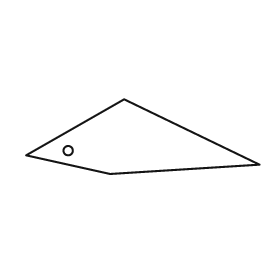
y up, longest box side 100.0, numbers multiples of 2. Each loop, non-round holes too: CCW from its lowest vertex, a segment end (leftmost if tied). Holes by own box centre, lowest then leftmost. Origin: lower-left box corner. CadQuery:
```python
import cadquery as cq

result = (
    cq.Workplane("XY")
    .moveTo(36.0, 0.0)
    .lineTo(100.0, 4.0)
    .lineTo(42.0, 32.0)
    .lineTo(0.0, 8.0)
    .close()
    .moveTo(18.0, 10.0)
    .circle(2.0)
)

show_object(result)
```